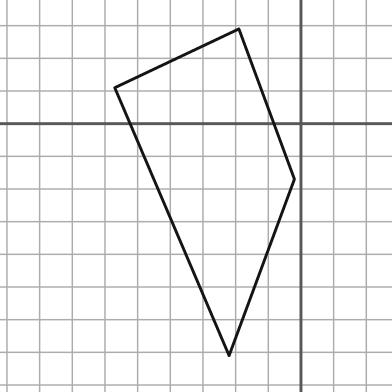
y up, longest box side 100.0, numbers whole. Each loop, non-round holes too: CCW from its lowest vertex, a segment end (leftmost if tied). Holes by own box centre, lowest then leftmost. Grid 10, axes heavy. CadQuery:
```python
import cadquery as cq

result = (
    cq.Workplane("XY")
    .moveTo(-22.0, -71.0)
    .lineTo(-2.0, -17.0)
    .lineTo(-19.0, 29.0)
    .lineTo(-57.0, 11.0)
    .close()
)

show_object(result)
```